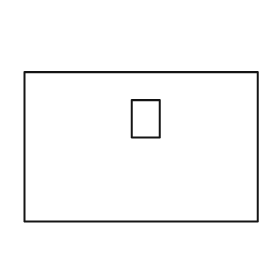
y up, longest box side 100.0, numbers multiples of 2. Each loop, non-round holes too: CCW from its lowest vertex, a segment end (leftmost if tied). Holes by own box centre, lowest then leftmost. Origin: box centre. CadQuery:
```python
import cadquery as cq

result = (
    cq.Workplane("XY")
    .moveTo(-50.0, -32.0)
    .lineTo(50.0, -32.0)
    .lineTo(50.0, 32.0)
    .lineTo(-50.0, 32.0)
    .close()
    .moveTo(-4.0, 4.0)
    .lineTo(8.0, 4.0)
    .lineTo(8.0, 20.0)
    .lineTo(-4.0, 20.0)
    .close()
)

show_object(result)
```